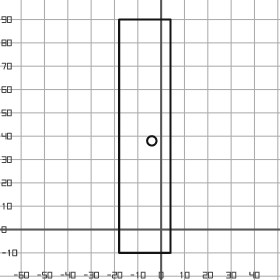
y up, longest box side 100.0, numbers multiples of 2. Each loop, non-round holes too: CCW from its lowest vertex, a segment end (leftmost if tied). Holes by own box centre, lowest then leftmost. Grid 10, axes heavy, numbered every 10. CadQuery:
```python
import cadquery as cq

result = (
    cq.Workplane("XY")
    .moveTo(-18.0, -10.0)
    .lineTo(4.0, -10.0)
    .lineTo(4.0, 90.0)
    .lineTo(-18.0, 90.0)
    .close()
    .moveTo(-4.0, 38.0)
    .circle(2.0)
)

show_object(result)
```